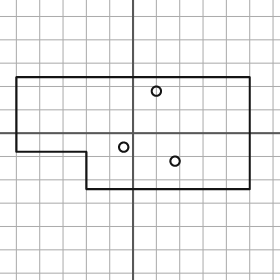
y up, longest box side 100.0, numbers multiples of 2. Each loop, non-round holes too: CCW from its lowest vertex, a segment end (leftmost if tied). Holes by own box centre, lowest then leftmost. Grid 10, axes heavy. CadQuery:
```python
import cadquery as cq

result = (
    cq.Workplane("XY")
    .moveTo(-20.0, -24.0)
    .lineTo(50.0, -24.0)
    .lineTo(50.0, 24.0)
    .lineTo(-50.0, 24.0)
    .lineTo(-50.0, -8.0)
    .lineTo(-20.0, -8.0)
    .close()
    .moveTo(18.0, -12.0)
    .circle(2.0)
    .moveTo(-4.0, -6.0)
    .circle(2.0)
    .moveTo(10.0, 18.0)
    .circle(2.0)
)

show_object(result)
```